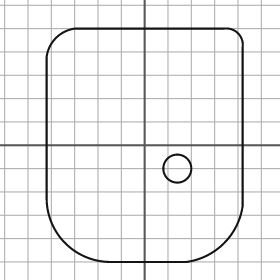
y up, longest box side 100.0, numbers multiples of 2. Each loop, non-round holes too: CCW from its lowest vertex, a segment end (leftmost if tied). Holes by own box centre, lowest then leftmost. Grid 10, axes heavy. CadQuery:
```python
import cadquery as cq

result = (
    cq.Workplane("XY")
    .moveTo(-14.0, -50.0)
    .lineTo(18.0, -50.0)
    .threePointArc((34.0, -42.0), (42.0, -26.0))
    .lineTo(42.0, 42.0)
    .threePointArc((40.0, 48.0), (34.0, 50.0))
    .lineTo(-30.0, 50.0)
    .threePointArc((-38.0, 46.0), (-42.0, 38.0))
    .lineTo(-42.0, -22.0)
    .threePointArc((-34.0, -42.0), (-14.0, -50.0))
    .close()
    .moveTo(14.0, -10.0)
    .circle(6.0)
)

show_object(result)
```